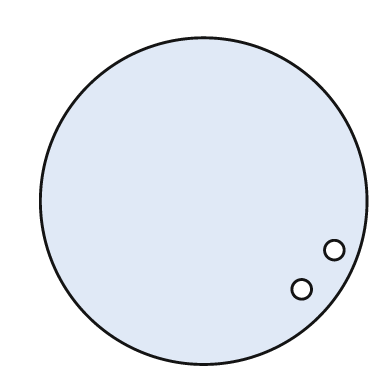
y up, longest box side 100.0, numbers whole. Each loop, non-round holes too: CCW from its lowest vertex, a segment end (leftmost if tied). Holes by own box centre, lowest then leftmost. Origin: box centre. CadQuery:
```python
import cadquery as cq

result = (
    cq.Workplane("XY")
    .moveTo(0.0, 0.0)
    .circle(50.0)
    .moveTo(30.0, -27.0)
    .circle(3.0)
    .moveTo(40.0, -15.0)
    .circle(3.0)
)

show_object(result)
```